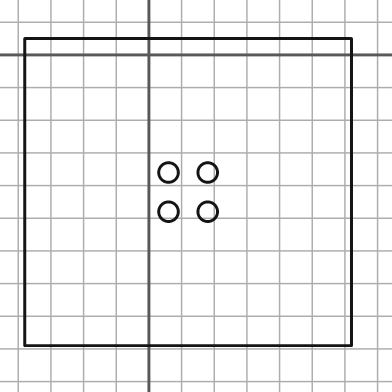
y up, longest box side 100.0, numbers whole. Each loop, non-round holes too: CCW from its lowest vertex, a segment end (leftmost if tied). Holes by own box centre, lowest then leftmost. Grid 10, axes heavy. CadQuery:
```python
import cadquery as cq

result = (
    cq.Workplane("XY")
    .moveTo(-38.0, -89.0)
    .lineTo(62.0, -89.0)
    .lineTo(62.0, 5.0)
    .lineTo(-38.0, 5.0)
    .close()
    .moveTo(6.0, -48.0)
    .circle(3.0)
    .moveTo(18.0, -48.0)
    .circle(3.0)
    .moveTo(6.0, -36.0)
    .circle(3.0)
    .moveTo(18.0, -36.0)
    .circle(3.0)
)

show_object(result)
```